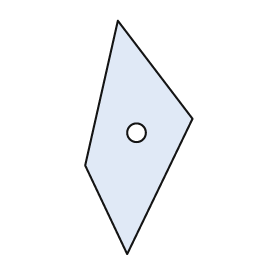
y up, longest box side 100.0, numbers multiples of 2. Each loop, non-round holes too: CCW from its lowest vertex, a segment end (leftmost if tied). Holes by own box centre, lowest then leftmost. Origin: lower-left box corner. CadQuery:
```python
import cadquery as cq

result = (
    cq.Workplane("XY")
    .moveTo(18.0, 0.0)
    .lineTo(46.0, 58.0)
    .lineTo(14.0, 100.0)
    .lineTo(0.0, 38.0)
    .close()
    .moveTo(22.0, 52.0)
    .circle(4.0)
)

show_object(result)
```